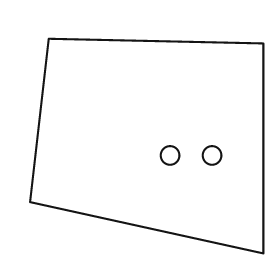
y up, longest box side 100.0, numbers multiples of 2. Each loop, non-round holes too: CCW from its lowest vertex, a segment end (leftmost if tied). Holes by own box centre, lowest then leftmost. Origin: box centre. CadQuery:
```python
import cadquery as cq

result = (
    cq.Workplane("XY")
    .moveTo(50.0, -46.0)
    .lineTo(50.0, 44.0)
    .lineTo(-42.0, 46.0)
    .lineTo(-50.0, -24.0)
    .close()
    .moveTo(10.0, -4.0)
    .circle(4.0)
    .moveTo(28.0, -4.0)
    .circle(4.0)
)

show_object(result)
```